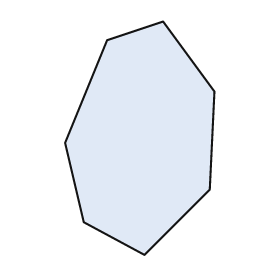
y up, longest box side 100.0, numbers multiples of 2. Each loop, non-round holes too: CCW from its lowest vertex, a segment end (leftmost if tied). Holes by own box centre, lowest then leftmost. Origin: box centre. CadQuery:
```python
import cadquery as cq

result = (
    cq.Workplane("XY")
    .moveTo(2.0, -50.0)
    .lineTo(30.0, -22.0)
    .lineTo(32.0, 20.0)
    .lineTo(10.0, 50.0)
    .lineTo(-14.0, 42.0)
    .lineTo(-32.0, -2.0)
    .lineTo(-24.0, -36.0)
    .close()
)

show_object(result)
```